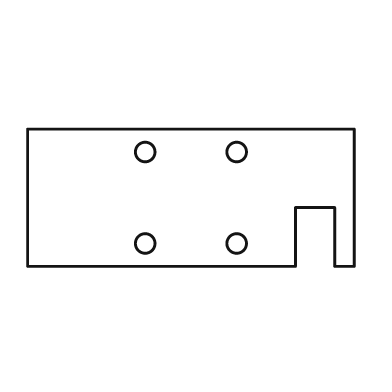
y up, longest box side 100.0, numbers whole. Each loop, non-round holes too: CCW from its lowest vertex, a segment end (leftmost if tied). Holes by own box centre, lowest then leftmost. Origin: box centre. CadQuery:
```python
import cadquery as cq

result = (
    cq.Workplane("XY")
    .moveTo(-50.0, -21.0)
    .lineTo(32.0, -21.0)
    .lineTo(32.0, -3.0)
    .lineTo(44.0, -3.0)
    .lineTo(44.0, -21.0)
    .lineTo(50.0, -21.0)
    .lineTo(50.0, 21.0)
    .lineTo(-50.0, 21.0)
    .close()
    .moveTo(-14.0, -14.0)
    .circle(3.0)
    .moveTo(14.0, -14.0)
    .circle(3.0)
    .moveTo(-14.0, 14.0)
    .circle(3.0)
    .moveTo(14.0, 14.0)
    .circle(3.0)
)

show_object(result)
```